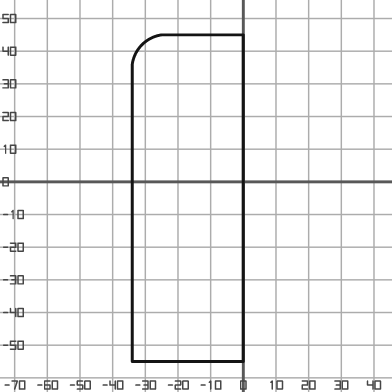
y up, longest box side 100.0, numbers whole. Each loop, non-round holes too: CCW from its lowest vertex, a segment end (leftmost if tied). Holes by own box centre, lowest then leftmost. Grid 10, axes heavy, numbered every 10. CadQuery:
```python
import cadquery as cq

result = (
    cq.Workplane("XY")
    .moveTo(-34.0, -55.0)
    .lineTo(0.0, -55.0)
    .lineTo(0.0, 45.0)
    .lineTo(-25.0, 45.0)
    .threePointArc((-31.0, 42.0), (-34.0, 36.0))
    .close()
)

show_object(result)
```